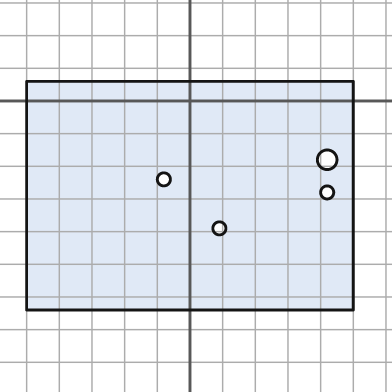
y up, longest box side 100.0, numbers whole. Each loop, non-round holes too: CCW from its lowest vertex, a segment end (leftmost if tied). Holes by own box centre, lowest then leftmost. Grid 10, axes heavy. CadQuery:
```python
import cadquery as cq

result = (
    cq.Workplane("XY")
    .moveTo(-50.0, -64.0)
    .lineTo(50.0, -64.0)
    .lineTo(50.0, 6.0)
    .lineTo(-50.0, 6.0)
    .close()
    .moveTo(9.0, -39.0)
    .circle(2.0)
    .moveTo(42.0, -28.0)
    .circle(2.0)
    .moveTo(-8.0, -24.0)
    .circle(2.0)
    .moveTo(42.0, -18.0)
    .circle(3.0)
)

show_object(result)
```